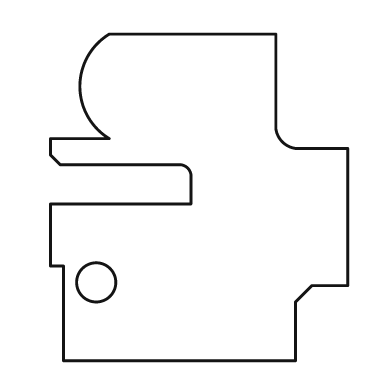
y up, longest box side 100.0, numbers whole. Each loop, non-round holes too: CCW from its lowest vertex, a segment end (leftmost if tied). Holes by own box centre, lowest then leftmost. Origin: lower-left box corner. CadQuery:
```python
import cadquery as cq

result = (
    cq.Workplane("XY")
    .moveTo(4.0, 0.0)
    .lineTo(75.0, 0.0)
    .lineTo(75.0, 18.0)
    .lineTo(80.0, 23.0)
    .lineTo(91.0, 23.0)
    .lineTo(91.0, 65.0)
    .lineTo(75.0, 65.0)
    .threePointArc((71.0, 67.0), (69.0, 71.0))
    .lineTo(69.0, 100.0)
    .lineTo(18.0, 100.0)
    .threePointArc((9.0, 84.0), (18.0, 68.0))
    .lineTo(0.0, 68.0)
    .lineTo(0.0, 63.0)
    .lineTo(3.0, 60.0)
    .lineTo(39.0, 60.0)
    .threePointArc((42.0, 59.0), (43.0, 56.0))
    .lineTo(43.0, 48.0)
    .lineTo(0.0, 48.0)
    .lineTo(0.0, 29.0)
    .lineTo(4.0, 29.0)
    .close()
    .moveTo(14.0, 24.0)
    .circle(6.0)
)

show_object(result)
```